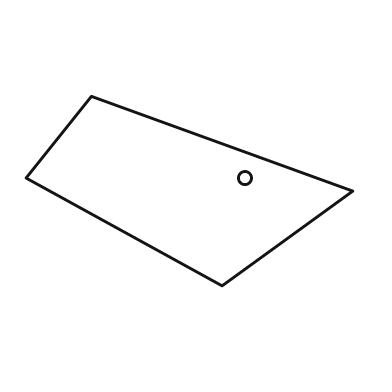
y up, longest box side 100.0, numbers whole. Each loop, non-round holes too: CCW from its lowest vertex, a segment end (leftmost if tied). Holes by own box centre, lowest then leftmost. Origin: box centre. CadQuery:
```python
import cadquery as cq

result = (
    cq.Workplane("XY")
    .moveTo(10.0, -29.0)
    .lineTo(50.0, 0.0)
    .lineTo(-30.0, 29.0)
    .lineTo(-50.0, 4.0)
    .close()
    .moveTo(17.0, 4.0)
    .circle(2.0)
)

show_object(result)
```